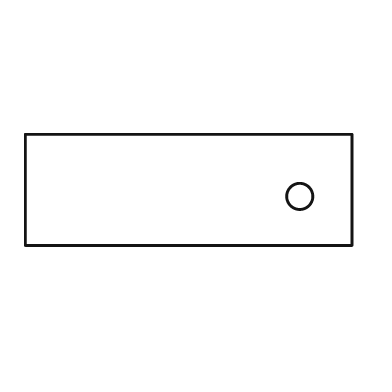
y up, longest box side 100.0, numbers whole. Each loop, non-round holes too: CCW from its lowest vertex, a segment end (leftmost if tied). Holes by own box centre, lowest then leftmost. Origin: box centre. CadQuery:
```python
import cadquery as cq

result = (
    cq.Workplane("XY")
    .moveTo(-50.0, -17.0)
    .lineTo(50.0, -17.0)
    .lineTo(50.0, 17.0)
    .lineTo(-50.0, 17.0)
    .close()
    .moveTo(34.0, -2.0)
    .circle(4.0)
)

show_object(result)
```